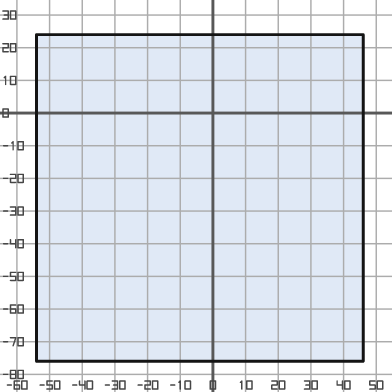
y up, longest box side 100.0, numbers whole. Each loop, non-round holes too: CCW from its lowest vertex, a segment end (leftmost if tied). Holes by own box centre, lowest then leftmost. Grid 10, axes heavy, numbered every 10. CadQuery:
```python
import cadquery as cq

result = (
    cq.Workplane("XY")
    .moveTo(-54.0, -76.0)
    .lineTo(46.0, -76.0)
    .lineTo(46.0, 24.0)
    .lineTo(-54.0, 24.0)
    .close()
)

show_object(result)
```